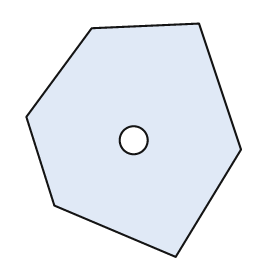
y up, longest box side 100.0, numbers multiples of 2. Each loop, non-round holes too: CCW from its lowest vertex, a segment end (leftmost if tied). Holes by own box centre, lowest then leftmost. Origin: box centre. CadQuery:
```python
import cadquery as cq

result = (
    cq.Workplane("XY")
    .moveTo(18.0, -50.0)
    .lineTo(46.0, -4.0)
    .lineTo(28.0, 50.0)
    .lineTo(-18.0, 48.0)
    .lineTo(-46.0, 10.0)
    .lineTo(-34.0, -28.0)
    .close()
    .moveTo(0.0, 0.0)
    .circle(6.0)
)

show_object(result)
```